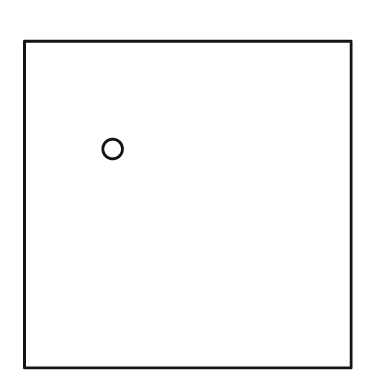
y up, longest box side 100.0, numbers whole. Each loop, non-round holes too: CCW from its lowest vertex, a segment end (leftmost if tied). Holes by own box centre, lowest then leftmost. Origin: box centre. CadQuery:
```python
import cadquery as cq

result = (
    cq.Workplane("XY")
    .moveTo(-50.0, -50.0)
    .lineTo(50.0, -50.0)
    .lineTo(50.0, 50.0)
    .lineTo(-50.0, 50.0)
    .close()
    .moveTo(-23.0, 17.0)
    .circle(3.0)
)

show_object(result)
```